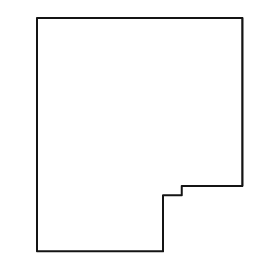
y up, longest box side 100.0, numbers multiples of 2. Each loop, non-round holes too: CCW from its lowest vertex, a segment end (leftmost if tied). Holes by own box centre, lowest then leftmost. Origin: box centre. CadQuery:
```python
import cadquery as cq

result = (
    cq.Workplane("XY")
    .moveTo(-44.0, -50.0)
    .lineTo(10.0, -50.0)
    .lineTo(10.0, -26.0)
    .lineTo(18.0, -26.0)
    .lineTo(18.0, -22.0)
    .lineTo(44.0, -22.0)
    .lineTo(44.0, 50.0)
    .lineTo(-44.0, 50.0)
    .close()
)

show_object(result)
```